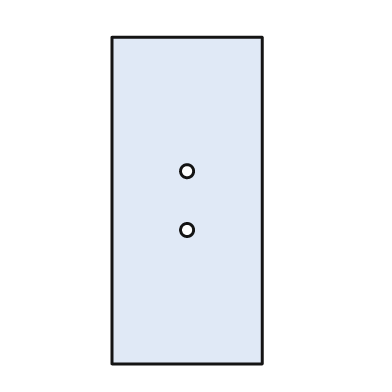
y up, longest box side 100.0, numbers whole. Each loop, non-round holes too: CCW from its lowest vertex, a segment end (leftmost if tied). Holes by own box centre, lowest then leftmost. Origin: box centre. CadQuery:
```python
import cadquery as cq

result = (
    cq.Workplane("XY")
    .moveTo(-23.0, -50.0)
    .lineTo(23.0, -50.0)
    .lineTo(23.0, 50.0)
    .lineTo(-23.0, 50.0)
    .close()
    .moveTo(0.0, -9.0)
    .circle(2.0)
    .moveTo(0.0, 9.0)
    .circle(2.0)
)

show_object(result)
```